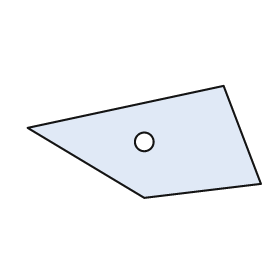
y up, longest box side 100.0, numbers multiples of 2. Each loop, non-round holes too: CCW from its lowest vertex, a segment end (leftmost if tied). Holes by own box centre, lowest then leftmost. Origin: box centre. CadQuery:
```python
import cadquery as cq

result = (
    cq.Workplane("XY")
    .moveTo(0.0, -24.0)
    .lineTo(50.0, -18.0)
    .lineTo(34.0, 24.0)
    .lineTo(-50.0, 6.0)
    .close()
    .moveTo(0.0, 0.0)
    .circle(4.0)
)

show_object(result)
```